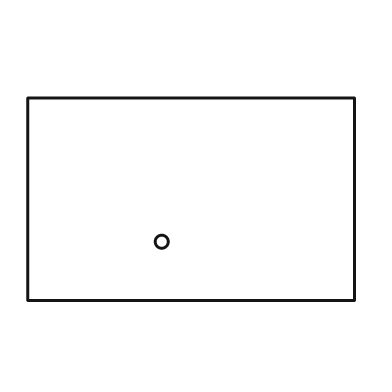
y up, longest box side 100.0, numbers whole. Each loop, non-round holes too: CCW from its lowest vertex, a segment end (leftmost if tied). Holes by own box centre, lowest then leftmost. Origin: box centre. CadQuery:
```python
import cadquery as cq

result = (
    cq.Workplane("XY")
    .moveTo(-50.0, -31.0)
    .lineTo(50.0, -31.0)
    .lineTo(50.0, 31.0)
    .lineTo(-50.0, 31.0)
    .close()
    .moveTo(-9.0, -13.0)
    .circle(2.0)
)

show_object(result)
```